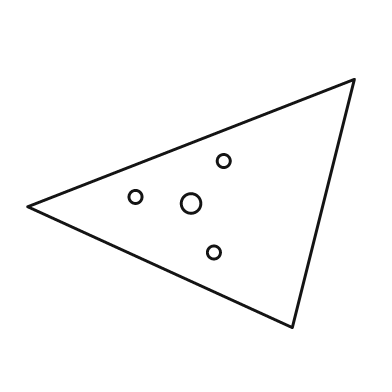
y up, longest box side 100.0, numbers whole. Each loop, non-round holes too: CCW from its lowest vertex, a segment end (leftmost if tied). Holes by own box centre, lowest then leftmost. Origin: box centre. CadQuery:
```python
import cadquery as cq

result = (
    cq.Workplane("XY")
    .moveTo(31.0, -38.0)
    .lineTo(50.0, 38.0)
    .lineTo(-50.0, -1.0)
    .close()
    .moveTo(7.0, -15.0)
    .circle(2.0)
    .moveTo(0.0, 0.0)
    .circle(3.0)
    .moveTo(-17.0, 2.0)
    .circle(2.0)
    .moveTo(10.0, 13.0)
    .circle(2.0)
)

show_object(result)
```